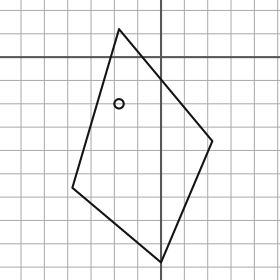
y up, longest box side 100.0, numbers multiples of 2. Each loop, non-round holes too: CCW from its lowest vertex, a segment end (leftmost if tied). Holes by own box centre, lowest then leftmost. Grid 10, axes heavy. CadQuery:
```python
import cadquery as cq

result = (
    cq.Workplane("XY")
    .moveTo(0.0, -88.0)
    .lineTo(22.0, -36.0)
    .lineTo(-18.0, 12.0)
    .lineTo(-38.0, -56.0)
    .close()
    .moveTo(-18.0, -20.0)
    .circle(2.0)
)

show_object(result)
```